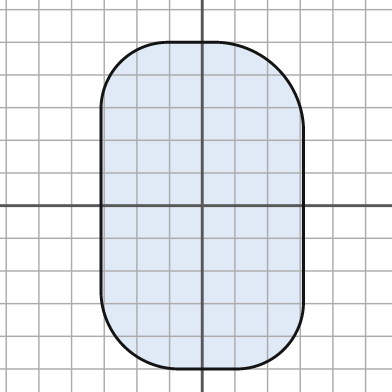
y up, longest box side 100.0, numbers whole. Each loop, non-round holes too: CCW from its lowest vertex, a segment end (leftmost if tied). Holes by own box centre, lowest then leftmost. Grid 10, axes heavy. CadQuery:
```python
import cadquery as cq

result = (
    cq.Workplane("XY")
    .moveTo(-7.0, -50.0)
    .lineTo(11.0, -50.0)
    .threePointArc((25.0, -44.0), (31.0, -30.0))
    .lineTo(31.0, 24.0)
    .threePointArc((23.0, 42.0), (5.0, 50.0))
    .lineTo(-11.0, 50.0)
    .threePointArc((-25.0, 44.0), (-31.0, 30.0))
    .lineTo(-31.0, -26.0)
    .threePointArc((-24.0, -43.0), (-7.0, -50.0))
    .close()
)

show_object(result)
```